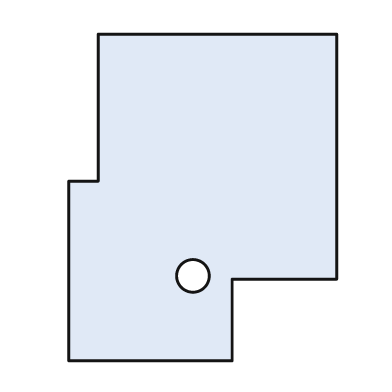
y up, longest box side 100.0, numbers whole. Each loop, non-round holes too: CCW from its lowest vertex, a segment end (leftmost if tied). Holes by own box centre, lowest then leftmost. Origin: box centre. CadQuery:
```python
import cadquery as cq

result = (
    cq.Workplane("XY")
    .moveTo(-41.0, -50.0)
    .lineTo(9.0, -50.0)
    .lineTo(9.0, -25.0)
    .lineTo(41.0, -25.0)
    .lineTo(41.0, 50.0)
    .lineTo(-32.0, 50.0)
    .lineTo(-32.0, 5.0)
    .lineTo(-41.0, 5.0)
    .close()
    .moveTo(-3.0, -24.0)
    .circle(5.0)
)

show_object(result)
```